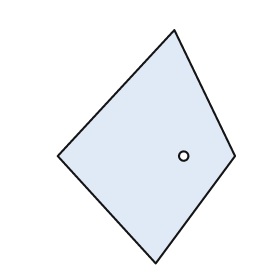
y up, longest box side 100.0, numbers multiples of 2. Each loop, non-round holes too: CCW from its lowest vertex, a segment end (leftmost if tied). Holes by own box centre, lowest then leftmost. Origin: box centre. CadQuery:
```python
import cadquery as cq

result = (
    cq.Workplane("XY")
    .moveTo(4.0, -50.0)
    .lineTo(38.0, -4.0)
    .lineTo(12.0, 50.0)
    .lineTo(-38.0, -4.0)
    .close()
    .moveTo(16.0, -4.0)
    .circle(2.0)
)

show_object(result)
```